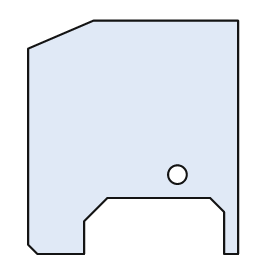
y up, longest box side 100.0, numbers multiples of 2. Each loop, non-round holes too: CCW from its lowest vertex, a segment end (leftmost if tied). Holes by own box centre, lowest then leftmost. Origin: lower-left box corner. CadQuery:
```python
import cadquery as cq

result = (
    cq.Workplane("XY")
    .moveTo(4.0, 0.0)
    .lineTo(24.0, 0.0)
    .lineTo(24.0, 14.0)
    .lineTo(34.0, 24.0)
    .lineTo(78.0, 24.0)
    .lineTo(84.0, 18.0)
    .lineTo(84.0, 0.0)
    .lineTo(90.0, 0.0)
    .lineTo(90.0, 100.0)
    .lineTo(28.0, 100.0)
    .lineTo(0.0, 88.0)
    .lineTo(0.0, 4.0)
    .close()
    .moveTo(64.0, 34.0)
    .circle(4.0)
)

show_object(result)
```